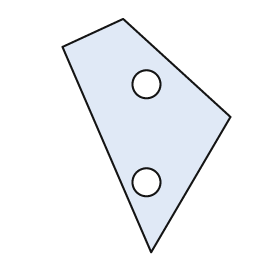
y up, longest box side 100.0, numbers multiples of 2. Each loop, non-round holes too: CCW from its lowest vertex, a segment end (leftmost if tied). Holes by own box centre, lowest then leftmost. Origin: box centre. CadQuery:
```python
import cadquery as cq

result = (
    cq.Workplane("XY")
    .moveTo(2.0, -50.0)
    .lineTo(36.0, 8.0)
    .lineTo(-10.0, 50.0)
    .lineTo(-36.0, 38.0)
    .close()
    .moveTo(0.0, -20.0)
    .circle(6.0)
    .moveTo(0.0, 22.0)
    .circle(6.0)
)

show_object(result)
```